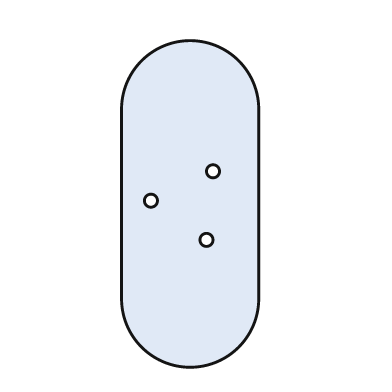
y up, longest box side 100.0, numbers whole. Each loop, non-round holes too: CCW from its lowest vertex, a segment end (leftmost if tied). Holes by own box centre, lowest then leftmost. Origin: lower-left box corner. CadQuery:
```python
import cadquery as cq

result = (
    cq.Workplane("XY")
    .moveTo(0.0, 21.0)
    .threePointArc((21.0, 0.0), (42.0, 21.0))
    .lineTo(42.0, 79.0)
    .threePointArc((21.0, 100.0), (0.0, 79.0))
    .close()
    .moveTo(26.0, 39.0)
    .circle(2.0)
    .moveTo(9.0, 51.0)
    .circle(2.0)
    .moveTo(28.0, 60.0)
    .circle(2.0)
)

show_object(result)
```